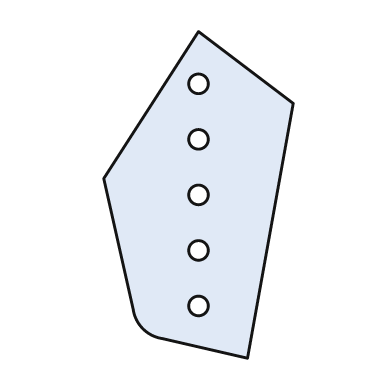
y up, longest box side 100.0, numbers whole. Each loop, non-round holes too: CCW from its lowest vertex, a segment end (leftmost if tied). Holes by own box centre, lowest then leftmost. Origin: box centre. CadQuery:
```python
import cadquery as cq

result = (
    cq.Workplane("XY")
    .moveTo(15.0, -50.0)
    .lineTo(29.0, 28.0)
    .lineTo(0.0, 50.0)
    .lineTo(-29.0, 5.0)
    .lineTo(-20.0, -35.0)
    .threePointArc((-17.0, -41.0), (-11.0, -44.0))
    .close()
    .moveTo(0.0, -34.0)
    .circle(3.0)
    .moveTo(0.0, -17.0)
    .circle(3.0)
    .moveTo(0.0, 0.0)
    .circle(3.0)
    .moveTo(0.0, 17.0)
    .circle(3.0)
    .moveTo(0.0, 34.0)
    .circle(3.0)
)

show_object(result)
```